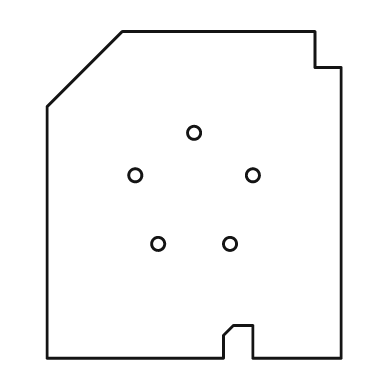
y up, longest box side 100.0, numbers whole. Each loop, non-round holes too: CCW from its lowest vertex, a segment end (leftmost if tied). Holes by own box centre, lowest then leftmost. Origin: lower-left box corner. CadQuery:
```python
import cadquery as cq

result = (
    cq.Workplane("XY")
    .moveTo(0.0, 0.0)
    .lineTo(54.0, 0.0)
    .lineTo(54.0, 7.0)
    .lineTo(57.0, 10.0)
    .lineTo(63.0, 10.0)
    .lineTo(63.0, 0.0)
    .lineTo(90.0, 0.0)
    .lineTo(90.0, 89.0)
    .lineTo(82.0, 89.0)
    .lineTo(82.0, 100.0)
    .lineTo(23.0, 100.0)
    .lineTo(0.0, 77.0)
    .close()
    .moveTo(34.0, 35.0)
    .circle(2.0)
    .moveTo(56.0, 35.0)
    .circle(2.0)
    .moveTo(27.0, 56.0)
    .circle(2.0)
    .moveTo(63.0, 56.0)
    .circle(2.0)
    .moveTo(45.0, 69.0)
    .circle(2.0)
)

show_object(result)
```